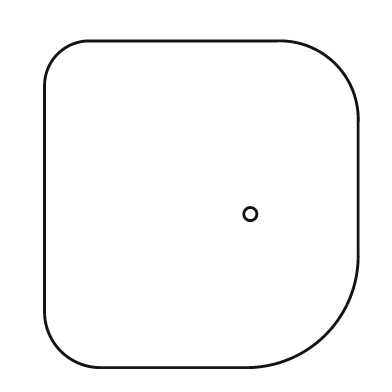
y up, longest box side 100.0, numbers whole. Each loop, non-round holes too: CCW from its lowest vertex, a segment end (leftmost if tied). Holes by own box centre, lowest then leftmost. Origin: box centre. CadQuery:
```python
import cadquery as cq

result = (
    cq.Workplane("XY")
    .moveTo(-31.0, -50.0)
    .lineTo(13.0, -50.0)
    .threePointArc((38.0, -40.0), (48.0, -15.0))
    .lineTo(48.0, 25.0)
    .threePointArc((41.0, 43.0), (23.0, 50.0))
    .lineTo(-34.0, 50.0)
    .threePointArc((-44.0, 46.0), (-48.0, 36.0))
    .lineTo(-48.0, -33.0)
    .threePointArc((-43.0, -45.0), (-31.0, -50.0))
    .close()
    .moveTo(15.0, -3.0)
    .circle(2.0)
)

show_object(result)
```